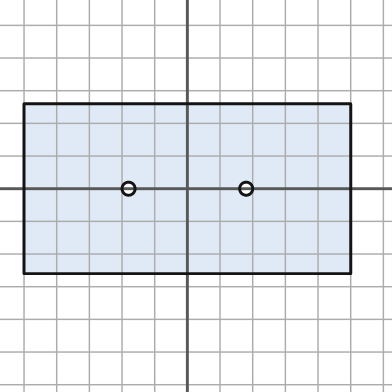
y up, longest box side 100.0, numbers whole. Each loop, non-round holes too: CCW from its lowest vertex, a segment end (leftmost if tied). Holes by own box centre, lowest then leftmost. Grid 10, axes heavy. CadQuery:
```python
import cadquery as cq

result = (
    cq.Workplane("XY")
    .moveTo(-50.0, -26.0)
    .lineTo(50.0, -26.0)
    .lineTo(50.0, 26.0)
    .lineTo(-50.0, 26.0)
    .close()
    .moveTo(-18.0, 0.0)
    .circle(2.0)
    .moveTo(18.0, 0.0)
    .circle(2.0)
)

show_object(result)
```